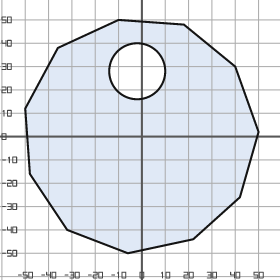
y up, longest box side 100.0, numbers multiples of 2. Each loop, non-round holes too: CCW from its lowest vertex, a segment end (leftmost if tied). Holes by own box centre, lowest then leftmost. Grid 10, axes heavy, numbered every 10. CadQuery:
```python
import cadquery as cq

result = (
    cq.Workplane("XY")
    .moveTo(-6.0, -50.0)
    .lineTo(22.0, -44.0)
    .lineTo(42.0, -26.0)
    .lineTo(50.0, 2.0)
    .lineTo(40.0, 30.0)
    .lineTo(18.0, 48.0)
    .lineTo(-10.0, 50.0)
    .lineTo(-36.0, 38.0)
    .lineTo(-50.0, 12.0)
    .lineTo(-48.0, -16.0)
    .lineTo(-32.0, -40.0)
    .close()
    .moveTo(-2.0, 28.0)
    .circle(12.0)
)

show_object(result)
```